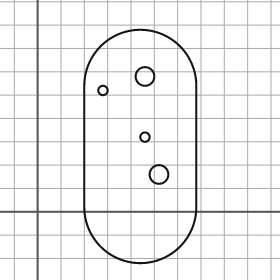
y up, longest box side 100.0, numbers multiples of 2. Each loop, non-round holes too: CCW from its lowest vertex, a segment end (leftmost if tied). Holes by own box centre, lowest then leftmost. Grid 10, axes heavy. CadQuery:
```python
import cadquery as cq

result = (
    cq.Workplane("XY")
    .moveTo(20.0, 2.0)
    .threePointArc((44.0, -22.0), (68.0, 2.0))
    .lineTo(68.0, 54.0)
    .threePointArc((44.0, 78.0), (20.0, 54.0))
    .close()
    .moveTo(52.0, 16.0)
    .circle(4.0)
    .moveTo(46.0, 32.0)
    .circle(2.0)
    .moveTo(28.0, 52.0)
    .circle(2.0)
    .moveTo(46.0, 58.0)
    .circle(4.0)
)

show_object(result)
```